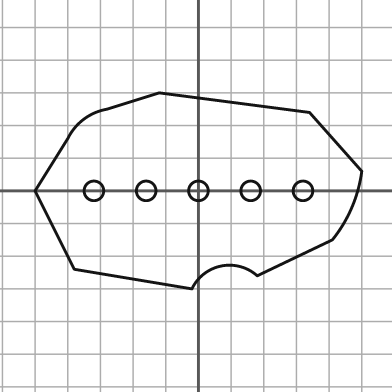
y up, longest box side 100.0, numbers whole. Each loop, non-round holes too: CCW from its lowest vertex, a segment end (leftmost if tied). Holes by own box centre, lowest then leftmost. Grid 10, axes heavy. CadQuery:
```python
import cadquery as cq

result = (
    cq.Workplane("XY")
    .moveTo(-2.0, -30.0)
    .threePointArc((7.0, -23.0), (18.0, -26.0))
    .lineTo(41.0, -15.0)
    .threePointArc((47.0, -5.0), (50.0, 6.0))
    .lineTo(34.0, 24.0)
    .lineTo(-12.0, 30.0)
    .lineTo(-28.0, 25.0)
    .threePointArc((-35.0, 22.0), (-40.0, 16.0))
    .lineTo(-50.0, 0.0)
    .lineTo(-38.0, -24.0)
    .close()
    .moveTo(-32.0, 0.0)
    .circle(3.0)
    .moveTo(-16.0, 0.0)
    .circle(3.0)
    .moveTo(0.0, 0.0)
    .circle(3.0)
    .moveTo(16.0, 0.0)
    .circle(3.0)
    .moveTo(32.0, 0.0)
    .circle(3.0)
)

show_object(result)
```